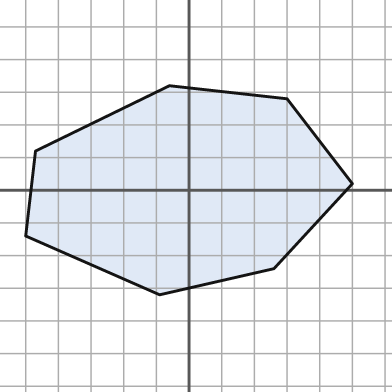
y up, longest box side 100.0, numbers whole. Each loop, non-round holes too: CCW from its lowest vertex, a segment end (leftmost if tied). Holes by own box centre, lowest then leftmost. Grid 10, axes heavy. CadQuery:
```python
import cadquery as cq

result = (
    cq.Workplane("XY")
    .moveTo(-9.0, -32.0)
    .lineTo(26.0, -24.0)
    .lineTo(50.0, 2.0)
    .lineTo(30.0, 28.0)
    .lineTo(-6.0, 32.0)
    .lineTo(-47.0, 12.0)
    .lineTo(-50.0, -14.0)
    .close()
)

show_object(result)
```